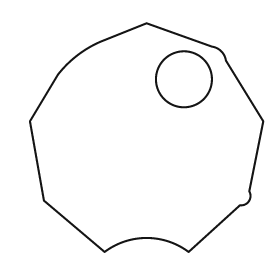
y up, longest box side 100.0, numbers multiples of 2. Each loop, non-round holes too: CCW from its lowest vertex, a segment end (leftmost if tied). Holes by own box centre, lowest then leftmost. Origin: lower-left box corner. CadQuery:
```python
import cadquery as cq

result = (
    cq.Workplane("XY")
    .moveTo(32.0, 0.0)
    .threePointArc((50.0, 6.0), (68.0, 0.0))
    .lineTo(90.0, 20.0)
    .threePointArc((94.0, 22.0), (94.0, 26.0))
    .lineTo(100.0, 56.0)
    .lineTo(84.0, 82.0)
    .threePointArc((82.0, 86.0), (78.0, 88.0))
    .lineTo(50.0, 98.0)
    .lineTo(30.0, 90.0)
    .threePointArc((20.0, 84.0), (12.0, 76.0))
    .lineTo(0.0, 56.0)
    .lineTo(6.0, 22.0)
    .close()
    .moveTo(66.0, 74.0)
    .circle(12.0)
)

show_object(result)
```